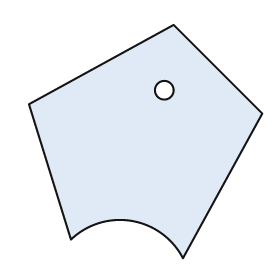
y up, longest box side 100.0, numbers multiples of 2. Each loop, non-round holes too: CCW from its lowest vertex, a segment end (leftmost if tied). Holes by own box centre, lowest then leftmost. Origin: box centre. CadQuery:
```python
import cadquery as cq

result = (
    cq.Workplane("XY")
    .moveTo(16.0, -50.0)
    .lineTo(50.0, 12.0)
    .lineTo(12.0, 50.0)
    .lineTo(-50.0, 16.0)
    .lineTo(-32.0, -42.0)
    .threePointArc((-6.0, -34.0), (16.0, -50.0))
    .close()
    .moveTo(8.0, 22.0)
    .circle(4.0)
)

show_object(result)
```